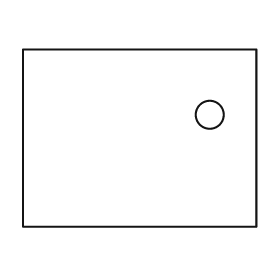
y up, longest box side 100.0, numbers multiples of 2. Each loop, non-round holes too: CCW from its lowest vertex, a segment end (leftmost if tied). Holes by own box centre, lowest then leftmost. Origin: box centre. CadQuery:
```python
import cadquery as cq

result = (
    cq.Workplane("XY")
    .moveTo(-50.0, -38.0)
    .lineTo(50.0, -38.0)
    .lineTo(50.0, 38.0)
    .lineTo(-50.0, 38.0)
    .close()
    .moveTo(30.0, 10.0)
    .circle(6.0)
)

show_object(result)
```